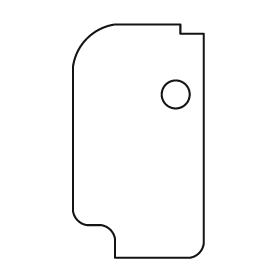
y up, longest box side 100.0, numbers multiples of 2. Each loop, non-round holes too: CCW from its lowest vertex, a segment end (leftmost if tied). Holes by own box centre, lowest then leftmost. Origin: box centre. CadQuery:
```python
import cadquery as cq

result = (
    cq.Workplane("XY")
    .moveTo(-10.0, -50.0)
    .lineTo(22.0, -50.0)
    .threePointArc((26.0, -48.0), (28.0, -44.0))
    .lineTo(28.0, 46.0)
    .lineTo(18.0, 46.0)
    .lineTo(18.0, 50.0)
    .lineTo(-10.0, 50.0)
    .threePointArc((-22.0, 44.0), (-28.0, 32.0))
    .lineTo(-28.0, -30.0)
    .threePointArc((-26.0, -34.0), (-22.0, -36.0))
    .lineTo(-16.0, -36.0)
    .threePointArc((-12.0, -38.0), (-10.0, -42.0))
    .close()
    .moveTo(16.0, 20.0)
    .circle(6.0)
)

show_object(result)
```